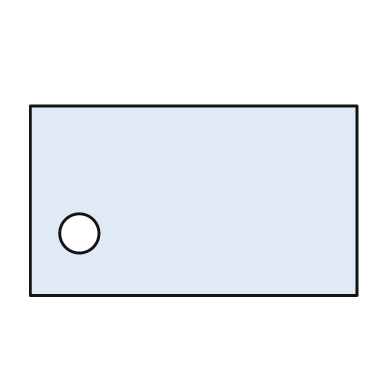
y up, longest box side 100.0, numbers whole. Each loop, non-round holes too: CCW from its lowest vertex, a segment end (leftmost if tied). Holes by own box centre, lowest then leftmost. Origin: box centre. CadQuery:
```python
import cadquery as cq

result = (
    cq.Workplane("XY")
    .moveTo(-50.0, -29.0)
    .lineTo(50.0, -29.0)
    .lineTo(50.0, 29.0)
    .lineTo(-50.0, 29.0)
    .close()
    .moveTo(-35.0, -10.0)
    .circle(6.0)
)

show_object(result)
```